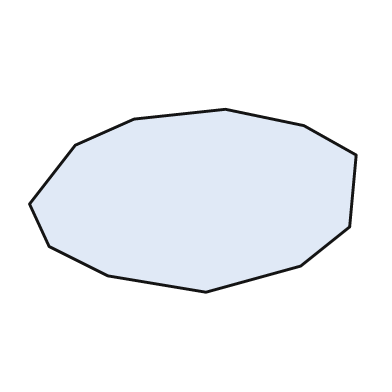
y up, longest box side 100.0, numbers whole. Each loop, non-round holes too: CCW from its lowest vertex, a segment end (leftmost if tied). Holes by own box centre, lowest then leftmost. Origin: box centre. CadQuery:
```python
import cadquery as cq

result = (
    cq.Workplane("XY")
    .moveTo(4.0, -28.0)
    .lineTo(33.0, -20.0)
    .lineTo(48.0, -8.0)
    .lineTo(50.0, 14.0)
    .lineTo(34.0, 23.0)
    .lineTo(10.0, 28.0)
    .lineTo(-18.0, 25.0)
    .lineTo(-36.0, 17.0)
    .lineTo(-50.0, -1.0)
    .lineTo(-44.0, -14.0)
    .lineTo(-26.0, -23.0)
    .close()
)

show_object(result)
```